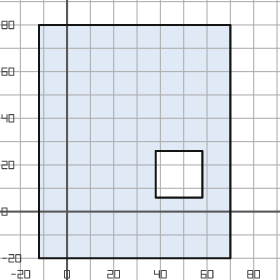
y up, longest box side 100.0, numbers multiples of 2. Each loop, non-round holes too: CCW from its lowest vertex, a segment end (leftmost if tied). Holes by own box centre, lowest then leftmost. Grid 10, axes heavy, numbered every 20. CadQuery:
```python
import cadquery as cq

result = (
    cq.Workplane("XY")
    .moveTo(-12.0, -20.0)
    .lineTo(70.0, -20.0)
    .lineTo(70.0, 80.0)
    .lineTo(-12.0, 80.0)
    .close()
    .moveTo(38.0, 6.0)
    .lineTo(58.0, 6.0)
    .lineTo(58.0, 26.0)
    .lineTo(38.0, 26.0)
    .close()
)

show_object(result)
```